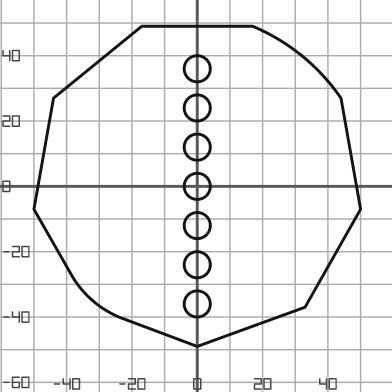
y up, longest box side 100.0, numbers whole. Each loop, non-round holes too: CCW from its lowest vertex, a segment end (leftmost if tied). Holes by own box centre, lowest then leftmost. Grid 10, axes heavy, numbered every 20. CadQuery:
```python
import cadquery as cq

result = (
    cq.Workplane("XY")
    .moveTo(0.0, -49.0)
    .lineTo(33.0, -37.0)
    .lineTo(50.0, -7.0)
    .lineTo(44.0, 27.0)
    .threePointArc((32.0, 40.0), (17.0, 49.0))
    .lineTo(-17.0, 49.0)
    .lineTo(-44.0, 27.0)
    .lineTo(-50.0, -7.0)
    .lineTo(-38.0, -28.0)
    .threePointArc((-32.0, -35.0), (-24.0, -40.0))
    .close()
    .moveTo(0.0, -36.0)
    .circle(4.0)
    .moveTo(0.0, -24.0)
    .circle(4.0)
    .moveTo(0.0, -12.0)
    .circle(4.0)
    .moveTo(0.0, 0.0)
    .circle(4.0)
    .moveTo(0.0, 12.0)
    .circle(4.0)
    .moveTo(0.0, 24.0)
    .circle(4.0)
    .moveTo(0.0, 36.0)
    .circle(4.0)
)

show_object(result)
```